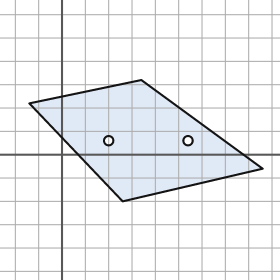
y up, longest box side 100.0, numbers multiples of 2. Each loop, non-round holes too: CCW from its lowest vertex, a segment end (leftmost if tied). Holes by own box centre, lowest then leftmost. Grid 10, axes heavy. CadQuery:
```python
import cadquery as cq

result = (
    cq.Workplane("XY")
    .moveTo(26.0, -20.0)
    .lineTo(86.0, -6.0)
    .lineTo(34.0, 32.0)
    .lineTo(-14.0, 22.0)
    .close()
    .moveTo(20.0, 6.0)
    .circle(2.0)
    .moveTo(54.0, 6.0)
    .circle(2.0)
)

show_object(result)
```